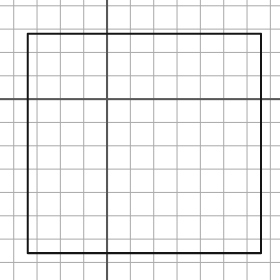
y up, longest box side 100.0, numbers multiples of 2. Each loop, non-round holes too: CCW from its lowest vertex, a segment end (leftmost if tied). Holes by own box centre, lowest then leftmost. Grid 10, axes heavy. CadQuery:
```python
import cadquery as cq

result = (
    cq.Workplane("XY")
    .moveTo(-34.0, -66.0)
    .lineTo(66.0, -66.0)
    .lineTo(66.0, 28.0)
    .lineTo(-34.0, 28.0)
    .close()
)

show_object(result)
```